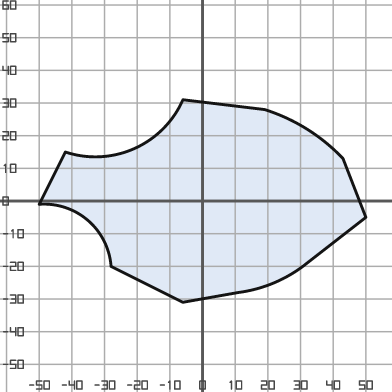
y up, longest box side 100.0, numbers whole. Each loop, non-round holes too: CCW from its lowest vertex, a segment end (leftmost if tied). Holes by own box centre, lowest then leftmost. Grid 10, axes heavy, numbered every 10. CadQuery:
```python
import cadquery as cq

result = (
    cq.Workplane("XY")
    .moveTo(-6.0, -31.0)
    .lineTo(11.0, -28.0)
    .threePointArc((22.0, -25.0), (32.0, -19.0))
    .lineTo(50.0, -5.0)
    .lineTo(43.0, 13.0)
    .threePointArc((32.0, 22.0), (19.0, 28.0))
    .lineTo(-6.0, 31.0)
    .threePointArc((-21.0, 16.0), (-42.0, 15.0))
    .lineTo(-50.0, -1.0)
    .threePointArc((-35.0, -6.0), (-28.0, -20.0))
    .close()
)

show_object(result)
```